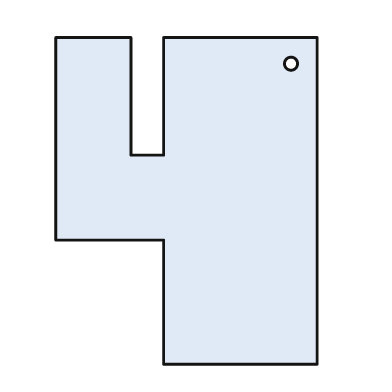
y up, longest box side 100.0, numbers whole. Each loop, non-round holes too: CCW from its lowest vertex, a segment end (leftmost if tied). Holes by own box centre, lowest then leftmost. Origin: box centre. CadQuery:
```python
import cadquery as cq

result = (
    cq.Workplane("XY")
    .moveTo(-7.0, -50.0)
    .lineTo(40.0, -50.0)
    .lineTo(40.0, 50.0)
    .lineTo(-7.0, 50.0)
    .lineTo(-7.0, 14.0)
    .lineTo(-17.0, 14.0)
    .lineTo(-17.0, 50.0)
    .lineTo(-40.0, 50.0)
    .lineTo(-40.0, -12.0)
    .lineTo(-7.0, -12.0)
    .close()
    .moveTo(32.0, 42.0)
    .circle(2.0)
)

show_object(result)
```